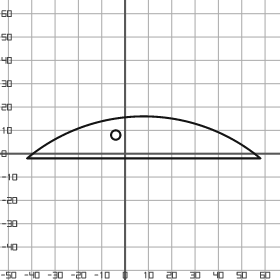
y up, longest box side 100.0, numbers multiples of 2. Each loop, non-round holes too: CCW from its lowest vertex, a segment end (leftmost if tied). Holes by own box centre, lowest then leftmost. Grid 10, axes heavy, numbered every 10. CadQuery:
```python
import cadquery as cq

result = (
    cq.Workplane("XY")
    .moveTo(-42.0, -2.0)
    .lineTo(58.0, -2.0)
    .threePointArc((8.0, 16.0), (-42.0, -2.0))
    .close()
    .moveTo(-4.0, 8.0)
    .circle(2.0)
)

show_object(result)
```